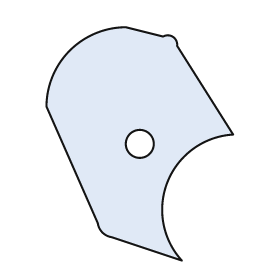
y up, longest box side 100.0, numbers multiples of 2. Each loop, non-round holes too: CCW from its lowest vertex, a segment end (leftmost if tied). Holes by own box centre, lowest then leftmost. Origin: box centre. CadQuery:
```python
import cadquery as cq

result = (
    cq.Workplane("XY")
    .moveTo(18.0, -50.0)
    .threePointArc((12.0, -16.0), (40.0, 4.0))
    .lineTo(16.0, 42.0)
    .threePointArc((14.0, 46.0), (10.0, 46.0))
    .lineTo(-6.0, 50.0)
    .threePointArc((-30.0, 40.0), (-40.0, 16.0))
    .lineTo(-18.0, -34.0)
    .threePointArc((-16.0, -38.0), (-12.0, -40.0))
    .close()
    .moveTo(0.0, 0.0)
    .circle(6.0)
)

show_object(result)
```